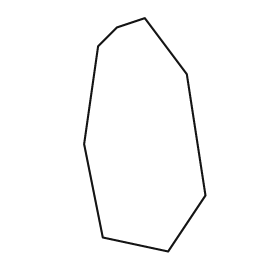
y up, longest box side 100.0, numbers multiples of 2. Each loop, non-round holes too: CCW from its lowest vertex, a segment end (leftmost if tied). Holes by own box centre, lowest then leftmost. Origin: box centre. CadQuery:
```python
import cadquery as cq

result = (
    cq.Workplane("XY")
    .moveTo(10.0, -50.0)
    .lineTo(26.0, -26.0)
    .lineTo(18.0, 26.0)
    .lineTo(0.0, 50.0)
    .lineTo(-12.0, 46.0)
    .lineTo(-20.0, 38.0)
    .lineTo(-26.0, -4.0)
    .lineTo(-18.0, -44.0)
    .close()
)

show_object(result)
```